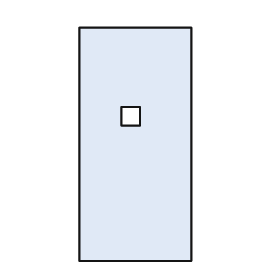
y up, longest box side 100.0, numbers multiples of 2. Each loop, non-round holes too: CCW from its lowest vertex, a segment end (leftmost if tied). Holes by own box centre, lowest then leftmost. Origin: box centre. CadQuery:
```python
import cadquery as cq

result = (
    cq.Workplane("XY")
    .moveTo(-24.0, -50.0)
    .lineTo(24.0, -50.0)
    .lineTo(24.0, 50.0)
    .lineTo(-24.0, 50.0)
    .close()
    .moveTo(-6.0, 8.0)
    .lineTo(2.0, 8.0)
    .lineTo(2.0, 16.0)
    .lineTo(-6.0, 16.0)
    .close()
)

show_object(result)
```